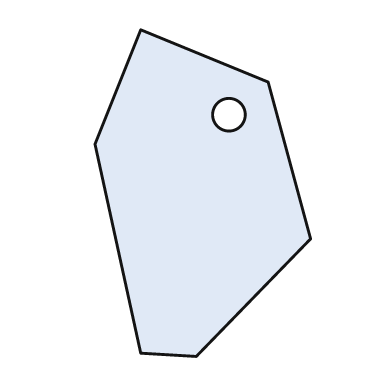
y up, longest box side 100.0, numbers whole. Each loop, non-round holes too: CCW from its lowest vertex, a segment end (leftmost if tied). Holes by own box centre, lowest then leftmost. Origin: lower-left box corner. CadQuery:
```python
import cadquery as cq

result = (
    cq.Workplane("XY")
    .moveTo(31.0, 0.0)
    .lineTo(66.0, 36.0)
    .lineTo(53.0, 84.0)
    .lineTo(14.0, 100.0)
    .lineTo(0.0, 65.0)
    .lineTo(14.0, 1.0)
    .close()
    .moveTo(41.0, 74.0)
    .circle(5.0)
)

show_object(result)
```